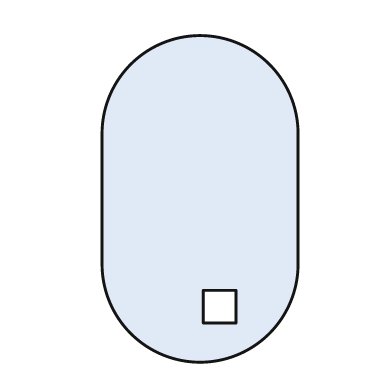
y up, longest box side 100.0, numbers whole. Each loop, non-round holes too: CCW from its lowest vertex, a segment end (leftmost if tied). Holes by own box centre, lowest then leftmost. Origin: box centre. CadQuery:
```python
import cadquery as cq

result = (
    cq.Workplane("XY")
    .moveTo(-30.0, -20.0)
    .threePointArc((0.0, -50.0), (30.0, -20.0))
    .lineTo(30.0, 20.0)
    .threePointArc((0.0, 50.0), (-30.0, 20.0))
    .close()
    .moveTo(1.0, -38.0)
    .lineTo(11.0, -38.0)
    .lineTo(11.0, -28.0)
    .lineTo(1.0, -28.0)
    .close()
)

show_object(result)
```